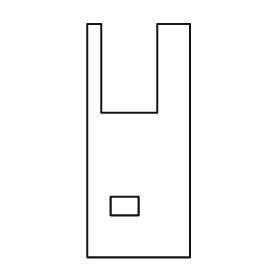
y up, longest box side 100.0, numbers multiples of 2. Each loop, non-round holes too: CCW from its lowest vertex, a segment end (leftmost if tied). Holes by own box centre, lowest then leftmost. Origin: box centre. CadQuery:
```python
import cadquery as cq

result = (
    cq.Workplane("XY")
    .moveTo(-22.0, -50.0)
    .lineTo(22.0, -50.0)
    .lineTo(22.0, 50.0)
    .lineTo(8.0, 50.0)
    .lineTo(8.0, 12.0)
    .lineTo(-16.0, 12.0)
    .lineTo(-16.0, 50.0)
    .lineTo(-22.0, 50.0)
    .close()
    .moveTo(-12.0, -32.0)
    .lineTo(0.0, -32.0)
    .lineTo(0.0, -24.0)
    .lineTo(-12.0, -24.0)
    .close()
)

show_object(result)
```